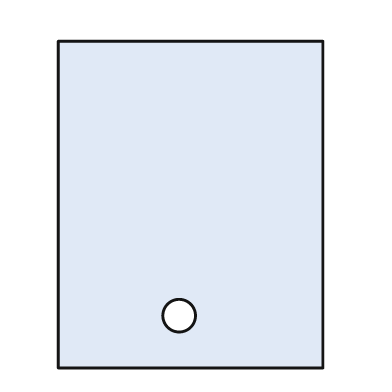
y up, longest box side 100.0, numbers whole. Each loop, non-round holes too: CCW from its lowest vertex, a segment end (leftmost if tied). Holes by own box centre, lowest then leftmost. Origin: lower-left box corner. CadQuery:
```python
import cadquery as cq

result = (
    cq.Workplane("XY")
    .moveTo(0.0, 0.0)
    .lineTo(81.0, 0.0)
    .lineTo(81.0, 100.0)
    .lineTo(0.0, 100.0)
    .close()
    .moveTo(37.0, 16.0)
    .circle(5.0)
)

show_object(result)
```